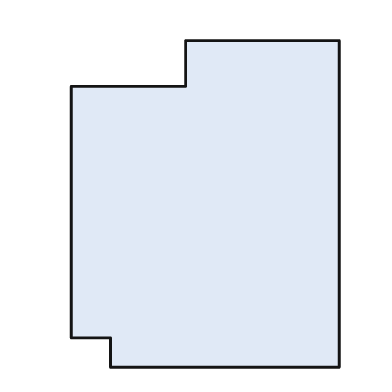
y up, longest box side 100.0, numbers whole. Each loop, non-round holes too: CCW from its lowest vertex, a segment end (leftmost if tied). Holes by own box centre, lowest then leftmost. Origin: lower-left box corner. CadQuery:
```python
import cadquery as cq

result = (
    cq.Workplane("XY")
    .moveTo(12.0, 0.0)
    .lineTo(82.0, 0.0)
    .lineTo(82.0, 100.0)
    .lineTo(35.0, 100.0)
    .lineTo(35.0, 86.0)
    .lineTo(0.0, 86.0)
    .lineTo(0.0, 9.0)
    .lineTo(12.0, 9.0)
    .close()
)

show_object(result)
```